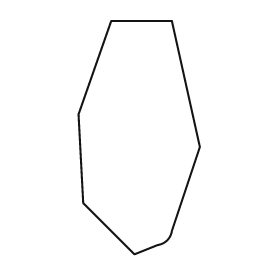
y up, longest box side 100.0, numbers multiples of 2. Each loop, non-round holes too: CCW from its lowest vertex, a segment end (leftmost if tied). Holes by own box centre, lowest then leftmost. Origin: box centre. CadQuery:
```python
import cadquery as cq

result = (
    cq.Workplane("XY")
    .moveTo(-2.0, -50.0)
    .lineTo(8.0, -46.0)
    .threePointArc((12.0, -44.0), (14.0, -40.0))
    .lineTo(26.0, -4.0)
    .lineTo(14.0, 50.0)
    .lineTo(-12.0, 50.0)
    .lineTo(-26.0, 10.0)
    .lineTo(-24.0, -28.0)
    .close()
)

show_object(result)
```